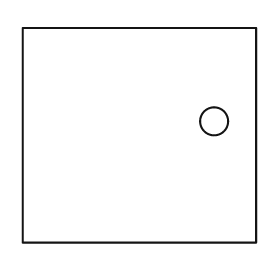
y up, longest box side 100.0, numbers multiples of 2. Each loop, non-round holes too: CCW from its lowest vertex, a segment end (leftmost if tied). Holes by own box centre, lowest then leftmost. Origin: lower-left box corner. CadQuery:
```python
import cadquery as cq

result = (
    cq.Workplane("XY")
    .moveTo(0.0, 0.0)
    .lineTo(100.0, 0.0)
    .lineTo(100.0, 92.0)
    .lineTo(0.0, 92.0)
    .close()
    .moveTo(82.0, 52.0)
    .circle(6.0)
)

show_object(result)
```